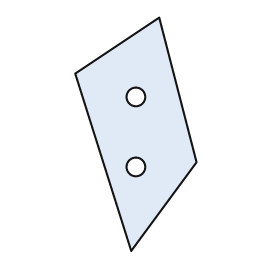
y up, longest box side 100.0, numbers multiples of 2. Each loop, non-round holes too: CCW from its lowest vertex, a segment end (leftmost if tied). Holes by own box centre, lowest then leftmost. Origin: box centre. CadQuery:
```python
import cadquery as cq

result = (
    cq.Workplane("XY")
    .moveTo(-2.0, -50.0)
    .lineTo(26.0, -12.0)
    .lineTo(10.0, 50.0)
    .lineTo(-26.0, 26.0)
    .close()
    .moveTo(0.0, -14.0)
    .circle(4.0)
    .moveTo(0.0, 16.0)
    .circle(4.0)
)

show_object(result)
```